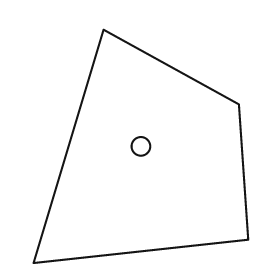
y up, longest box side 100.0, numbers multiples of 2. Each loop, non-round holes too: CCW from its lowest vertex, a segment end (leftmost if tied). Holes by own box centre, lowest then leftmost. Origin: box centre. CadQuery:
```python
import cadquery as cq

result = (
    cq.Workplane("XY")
    .moveTo(-46.0, -50.0)
    .lineTo(46.0, -40.0)
    .lineTo(42.0, 18.0)
    .lineTo(-16.0, 50.0)
    .close()
    .moveTo(0.0, 0.0)
    .circle(4.0)
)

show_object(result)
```